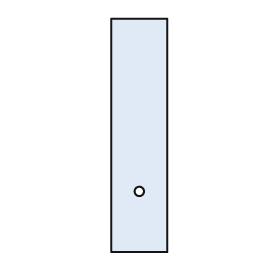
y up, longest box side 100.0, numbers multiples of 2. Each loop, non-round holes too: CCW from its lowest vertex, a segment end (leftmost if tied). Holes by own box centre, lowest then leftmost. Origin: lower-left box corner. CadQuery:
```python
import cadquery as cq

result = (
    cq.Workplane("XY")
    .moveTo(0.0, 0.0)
    .lineTo(24.0, 0.0)
    .lineTo(24.0, 100.0)
    .lineTo(0.0, 100.0)
    .close()
    .moveTo(12.0, 26.0)
    .circle(2.0)
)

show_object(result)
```